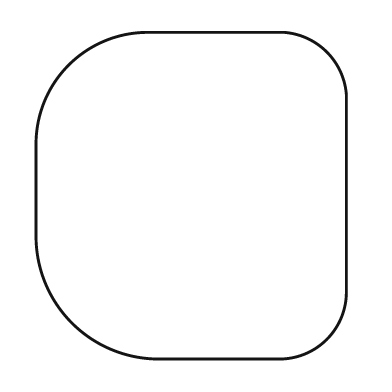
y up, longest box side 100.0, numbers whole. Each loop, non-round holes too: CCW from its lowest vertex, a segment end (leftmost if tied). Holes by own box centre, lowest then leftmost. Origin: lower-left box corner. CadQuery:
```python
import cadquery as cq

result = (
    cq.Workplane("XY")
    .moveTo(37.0, 0.0)
    .lineTo(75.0, 0.0)
    .threePointArc((89.0, 6.0), (95.0, 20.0))
    .lineTo(95.0, 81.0)
    .threePointArc((89.0, 94.0), (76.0, 100.0))
    .lineTo(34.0, 100.0)
    .threePointArc((10.0, 90.0), (0.0, 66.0))
    .lineTo(0.0, 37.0)
    .threePointArc((11.0, 11.0), (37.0, 0.0))
    .close()
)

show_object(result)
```